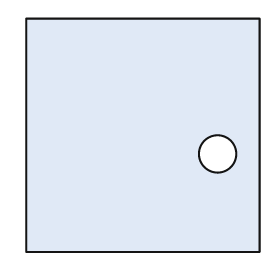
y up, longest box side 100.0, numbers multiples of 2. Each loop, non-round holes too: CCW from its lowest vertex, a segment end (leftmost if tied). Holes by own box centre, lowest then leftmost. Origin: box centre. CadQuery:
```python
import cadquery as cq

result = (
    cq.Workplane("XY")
    .moveTo(-50.0, -50.0)
    .lineTo(50.0, -50.0)
    .lineTo(50.0, 50.0)
    .lineTo(-50.0, 50.0)
    .close()
    .moveTo(32.0, -8.0)
    .circle(8.0)
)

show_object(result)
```